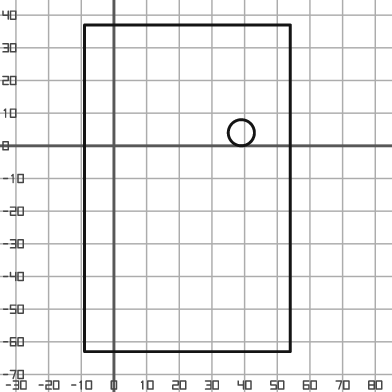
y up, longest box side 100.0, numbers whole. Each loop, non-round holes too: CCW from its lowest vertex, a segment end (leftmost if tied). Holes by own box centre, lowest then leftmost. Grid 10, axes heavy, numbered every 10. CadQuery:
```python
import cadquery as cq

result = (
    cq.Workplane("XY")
    .moveTo(-9.0, -63.0)
    .lineTo(54.0, -63.0)
    .lineTo(54.0, 37.0)
    .lineTo(-9.0, 37.0)
    .close()
    .moveTo(39.0, 4.0)
    .circle(4.0)
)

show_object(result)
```